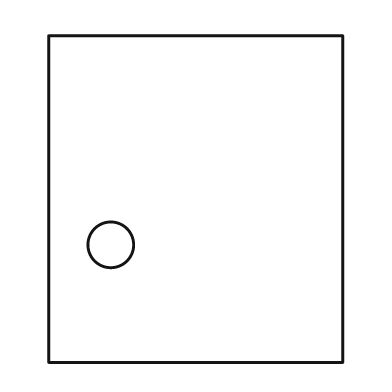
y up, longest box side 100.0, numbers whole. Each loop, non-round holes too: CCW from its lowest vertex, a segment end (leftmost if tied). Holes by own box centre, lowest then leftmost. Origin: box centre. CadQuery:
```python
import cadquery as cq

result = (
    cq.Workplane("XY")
    .moveTo(-45.0, -50.0)
    .lineTo(45.0, -50.0)
    .lineTo(45.0, 50.0)
    .lineTo(-45.0, 50.0)
    .close()
    .moveTo(-26.0, -14.0)
    .circle(7.0)
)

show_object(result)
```